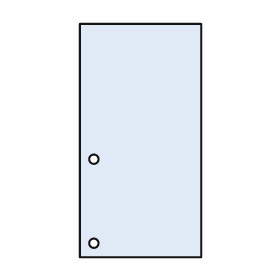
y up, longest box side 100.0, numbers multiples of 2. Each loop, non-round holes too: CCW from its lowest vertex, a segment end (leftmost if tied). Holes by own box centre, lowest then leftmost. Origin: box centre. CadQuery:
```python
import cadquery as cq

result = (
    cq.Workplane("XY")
    .moveTo(-26.0, -50.0)
    .lineTo(26.0, -50.0)
    .lineTo(26.0, 50.0)
    .lineTo(-26.0, 50.0)
    .close()
    .moveTo(-20.0, -44.0)
    .circle(2.0)
    .moveTo(-20.0, -8.0)
    .circle(2.0)
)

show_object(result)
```